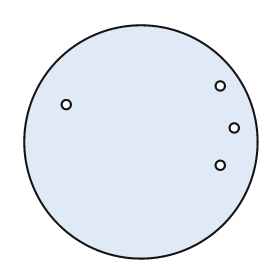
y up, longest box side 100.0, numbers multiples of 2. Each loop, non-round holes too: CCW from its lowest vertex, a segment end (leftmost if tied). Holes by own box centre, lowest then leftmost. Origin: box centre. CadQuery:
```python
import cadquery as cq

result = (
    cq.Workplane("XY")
    .moveTo(0.0, 0.0)
    .circle(50.0)
    .moveTo(34.0, -10.0)
    .circle(2.0)
    .moveTo(40.0, 6.0)
    .circle(2.0)
    .moveTo(-32.0, 16.0)
    .circle(2.0)
    .moveTo(34.0, 24.0)
    .circle(2.0)
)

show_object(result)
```